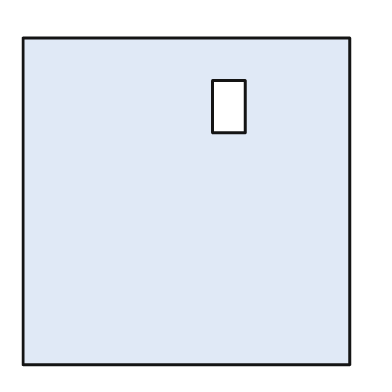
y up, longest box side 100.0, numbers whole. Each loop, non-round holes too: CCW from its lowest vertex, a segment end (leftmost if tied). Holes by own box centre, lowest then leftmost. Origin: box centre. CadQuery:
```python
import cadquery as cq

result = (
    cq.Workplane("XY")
    .moveTo(-50.0, -50.0)
    .lineTo(50.0, -50.0)
    .lineTo(50.0, 50.0)
    .lineTo(-50.0, 50.0)
    .close()
    .moveTo(8.0, 21.0)
    .lineTo(18.0, 21.0)
    .lineTo(18.0, 37.0)
    .lineTo(8.0, 37.0)
    .close()
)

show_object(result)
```